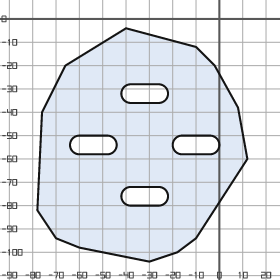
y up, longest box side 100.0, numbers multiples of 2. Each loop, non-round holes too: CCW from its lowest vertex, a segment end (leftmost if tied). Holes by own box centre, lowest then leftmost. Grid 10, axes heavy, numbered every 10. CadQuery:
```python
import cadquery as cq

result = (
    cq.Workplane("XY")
    .moveTo(-30.0, -104.0)
    .lineTo(-18.0, -100.0)
    .lineTo(-10.0, -94.0)
    .lineTo(12.0, -60.0)
    .lineTo(8.0, -38.0)
    .lineTo(-2.0, -20.0)
    .lineTo(-10.0, -12.0)
    .lineTo(-40.0, -4.0)
    .lineTo(-66.0, -20.0)
    .lineTo(-76.0, -40.0)
    .lineTo(-78.0, -82.0)
    .lineTo(-70.0, -94.0)
    .lineTo(-60.0, -98.0)
    .close()
    .moveTo(-38.0, -80.0)
    .lineTo(-26.0, -80.0)
    .threePointArc((-22.0, -76.0), (-26.0, -72.0))
    .lineTo(-38.0, -72.0)
    .threePointArc((-42.0, -76.0), (-38.0, -80.0))
    .close()
    .moveTo(-60.0, -58.0)
    .lineTo(-48.0, -58.0)
    .threePointArc((-44.0, -54.0), (-48.0, -50.0))
    .lineTo(-60.0, -50.0)
    .threePointArc((-64.0, -54.0), (-60.0, -58.0))
    .close()
    .moveTo(-16.0, -58.0)
    .lineTo(-4.0, -58.0)
    .threePointArc((0.0, -54.0), (-4.0, -50.0))
    .lineTo(-16.0, -50.0)
    .threePointArc((-20.0, -54.0), (-16.0, -58.0))
    .close()
    .moveTo(-38.0, -36.0)
    .lineTo(-26.0, -36.0)
    .threePointArc((-22.0, -32.0), (-26.0, -28.0))
    .lineTo(-38.0, -28.0)
    .threePointArc((-42.0, -32.0), (-38.0, -36.0))
    .close()
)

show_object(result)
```